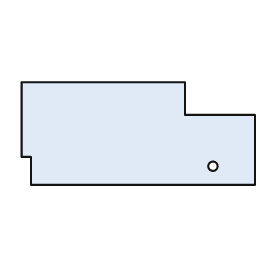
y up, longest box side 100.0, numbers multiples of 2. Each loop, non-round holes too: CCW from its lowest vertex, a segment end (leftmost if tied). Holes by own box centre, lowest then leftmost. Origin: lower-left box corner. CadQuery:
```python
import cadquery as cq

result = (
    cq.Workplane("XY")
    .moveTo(4.0, 0.0)
    .lineTo(100.0, 0.0)
    .lineTo(100.0, 30.0)
    .lineTo(70.0, 30.0)
    .lineTo(70.0, 44.0)
    .lineTo(0.0, 44.0)
    .lineTo(0.0, 12.0)
    .lineTo(4.0, 12.0)
    .close()
    .moveTo(82.0, 8.0)
    .circle(2.0)
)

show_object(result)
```